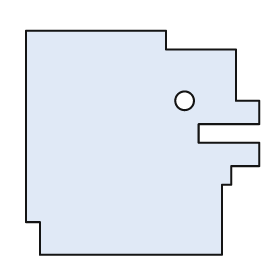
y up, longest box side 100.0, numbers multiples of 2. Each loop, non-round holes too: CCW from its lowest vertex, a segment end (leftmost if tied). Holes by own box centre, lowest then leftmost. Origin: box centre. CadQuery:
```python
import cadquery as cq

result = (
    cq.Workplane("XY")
    .moveTo(-44.0, -48.0)
    .lineTo(34.0, -48.0)
    .lineTo(34.0, -18.0)
    .lineTo(38.0, -18.0)
    .lineTo(38.0, -10.0)
    .lineTo(50.0, -10.0)
    .lineTo(50.0, 0.0)
    .lineTo(24.0, 0.0)
    .lineTo(24.0, 8.0)
    .lineTo(50.0, 8.0)
    .lineTo(50.0, 18.0)
    .lineTo(40.0, 18.0)
    .lineTo(40.0, 40.0)
    .lineTo(10.0, 40.0)
    .lineTo(10.0, 48.0)
    .lineTo(-50.0, 48.0)
    .lineTo(-50.0, -34.0)
    .lineTo(-44.0, -34.0)
    .close()
    .moveTo(18.0, 18.0)
    .circle(4.0)
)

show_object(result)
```